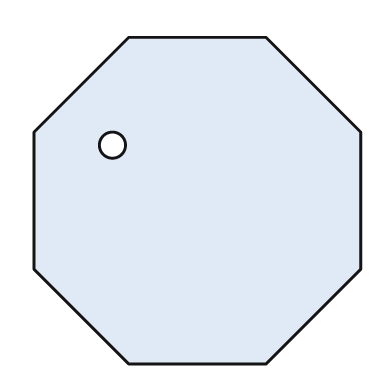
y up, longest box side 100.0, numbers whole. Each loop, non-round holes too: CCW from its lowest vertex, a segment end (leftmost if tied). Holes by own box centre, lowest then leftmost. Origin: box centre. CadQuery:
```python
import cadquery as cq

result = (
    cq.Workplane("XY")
    .moveTo(-21.0, -50.0)
    .lineTo(21.0, -50.0)
    .lineTo(50.0, -21.0)
    .lineTo(50.0, 21.0)
    .lineTo(21.0, 50.0)
    .lineTo(-21.0, 50.0)
    .lineTo(-50.0, 21.0)
    .lineTo(-50.0, -21.0)
    .close()
    .moveTo(-26.0, 17.0)
    .circle(4.0)
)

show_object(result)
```